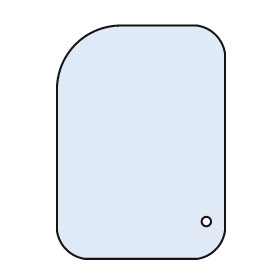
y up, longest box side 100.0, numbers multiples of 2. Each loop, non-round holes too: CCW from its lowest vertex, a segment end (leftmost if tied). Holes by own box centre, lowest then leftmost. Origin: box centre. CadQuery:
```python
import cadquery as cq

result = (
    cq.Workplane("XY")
    .moveTo(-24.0, -50.0)
    .lineTo(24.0, -50.0)
    .threePointArc((32.0, -46.0), (36.0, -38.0))
    .lineTo(36.0, 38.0)
    .threePointArc((32.0, 46.0), (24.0, 50.0))
    .lineTo(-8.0, 50.0)
    .threePointArc((-28.0, 42.0), (-36.0, 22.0))
    .lineTo(-36.0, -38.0)
    .threePointArc((-32.0, -46.0), (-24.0, -50.0))
    .close()
    .moveTo(28.0, -34.0)
    .circle(2.0)
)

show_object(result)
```